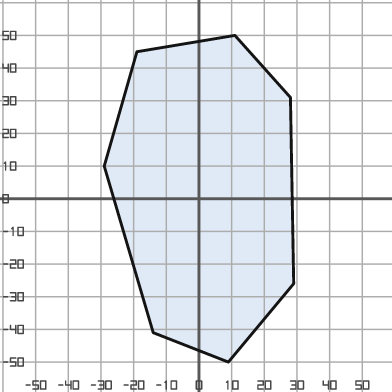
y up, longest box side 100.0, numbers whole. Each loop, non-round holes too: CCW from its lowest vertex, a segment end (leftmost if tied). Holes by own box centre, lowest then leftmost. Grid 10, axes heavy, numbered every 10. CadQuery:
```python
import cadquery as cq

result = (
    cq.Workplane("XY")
    .moveTo(9.0, -50.0)
    .lineTo(29.0, -26.0)
    .lineTo(28.0, 31.0)
    .lineTo(11.0, 50.0)
    .lineTo(-19.0, 45.0)
    .lineTo(-29.0, 10.0)
    .lineTo(-14.0, -41.0)
    .close()
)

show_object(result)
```